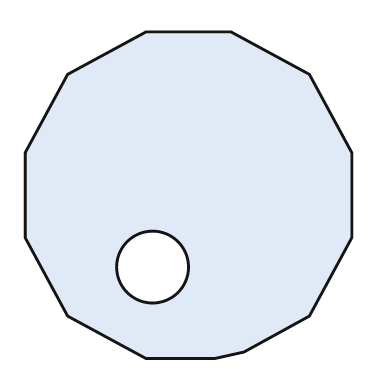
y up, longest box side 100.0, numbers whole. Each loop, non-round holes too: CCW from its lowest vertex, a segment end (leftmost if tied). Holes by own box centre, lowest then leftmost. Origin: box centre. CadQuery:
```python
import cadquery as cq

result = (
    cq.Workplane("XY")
    .moveTo(-13.0, -50.0)
    .lineTo(8.0, -50.0)
    .lineTo(17.0, -48.0)
    .lineTo(37.0, -37.0)
    .lineTo(50.0, -13.0)
    .lineTo(50.0, 13.0)
    .lineTo(37.0, 37.0)
    .lineTo(13.0, 50.0)
    .lineTo(-13.0, 50.0)
    .lineTo(-37.0, 37.0)
    .lineTo(-50.0, 13.0)
    .lineTo(-50.0, -13.0)
    .lineTo(-37.0, -37.0)
    .close()
    .moveTo(-11.0, -22.0)
    .circle(11.0)
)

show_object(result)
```